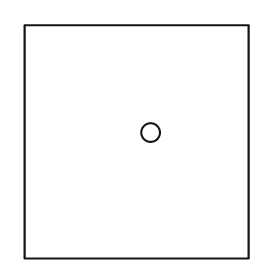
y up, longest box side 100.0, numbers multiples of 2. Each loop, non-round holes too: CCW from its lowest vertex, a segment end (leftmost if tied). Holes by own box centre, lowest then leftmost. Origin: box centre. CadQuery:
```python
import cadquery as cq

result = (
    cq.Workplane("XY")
    .moveTo(-48.0, -50.0)
    .lineTo(48.0, -50.0)
    .lineTo(48.0, 50.0)
    .lineTo(-48.0, 50.0)
    .close()
    .moveTo(6.0, 4.0)
    .circle(4.0)
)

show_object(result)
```